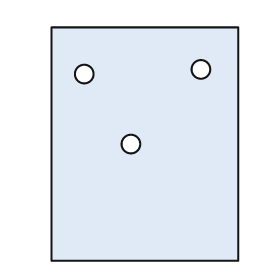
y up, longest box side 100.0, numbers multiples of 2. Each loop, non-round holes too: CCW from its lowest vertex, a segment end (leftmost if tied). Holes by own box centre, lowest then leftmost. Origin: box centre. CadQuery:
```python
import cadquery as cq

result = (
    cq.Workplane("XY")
    .moveTo(-40.0, -50.0)
    .lineTo(40.0, -50.0)
    .lineTo(40.0, 50.0)
    .lineTo(-40.0, 50.0)
    .close()
    .moveTo(-6.0, 0.0)
    .circle(4.0)
    .moveTo(-26.0, 30.0)
    .circle(4.0)
    .moveTo(24.0, 32.0)
    .circle(4.0)
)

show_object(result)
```